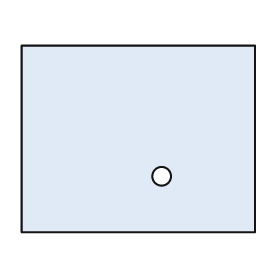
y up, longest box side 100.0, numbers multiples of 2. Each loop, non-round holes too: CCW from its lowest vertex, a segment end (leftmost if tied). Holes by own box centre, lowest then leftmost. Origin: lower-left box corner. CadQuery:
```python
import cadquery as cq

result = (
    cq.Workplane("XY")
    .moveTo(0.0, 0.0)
    .lineTo(100.0, 0.0)
    .lineTo(100.0, 80.0)
    .lineTo(0.0, 80.0)
    .close()
    .moveTo(60.0, 24.0)
    .circle(4.0)
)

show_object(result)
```